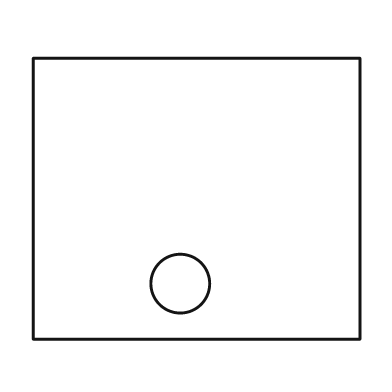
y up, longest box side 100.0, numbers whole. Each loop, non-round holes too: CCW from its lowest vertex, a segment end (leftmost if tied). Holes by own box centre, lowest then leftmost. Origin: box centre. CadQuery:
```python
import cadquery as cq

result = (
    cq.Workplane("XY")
    .moveTo(-50.0, -43.0)
    .lineTo(50.0, -43.0)
    .lineTo(50.0, 43.0)
    .lineTo(-50.0, 43.0)
    .close()
    .moveTo(-5.0, -26.0)
    .circle(9.0)
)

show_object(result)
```